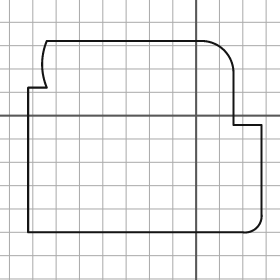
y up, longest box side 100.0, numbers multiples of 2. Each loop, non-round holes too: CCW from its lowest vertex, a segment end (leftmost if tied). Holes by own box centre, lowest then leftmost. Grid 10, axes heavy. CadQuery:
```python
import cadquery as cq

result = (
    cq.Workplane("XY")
    .moveTo(-72.0, -50.0)
    .lineTo(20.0, -50.0)
    .threePointArc((26.0, -48.0), (28.0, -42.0))
    .lineTo(28.0, -4.0)
    .lineTo(16.0, -4.0)
    .lineTo(16.0, 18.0)
    .threePointArc((12.0, 28.0), (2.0, 32.0))
    .lineTo(-64.0, 32.0)
    .threePointArc((-66.0, 22.0), (-64.0, 12.0))
    .lineTo(-72.0, 12.0)
    .close()
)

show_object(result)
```